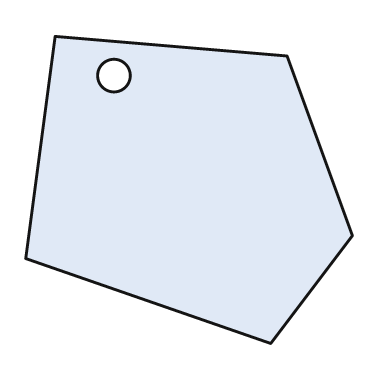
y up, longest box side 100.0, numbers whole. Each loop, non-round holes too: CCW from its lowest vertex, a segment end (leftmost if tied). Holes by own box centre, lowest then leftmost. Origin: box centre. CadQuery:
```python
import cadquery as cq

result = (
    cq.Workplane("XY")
    .moveTo(25.0, -47.0)
    .lineTo(50.0, -14.0)
    .lineTo(30.0, 41.0)
    .lineTo(-41.0, 47.0)
    .lineTo(-50.0, -21.0)
    .close()
    .moveTo(-23.0, 35.0)
    .circle(5.0)
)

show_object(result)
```